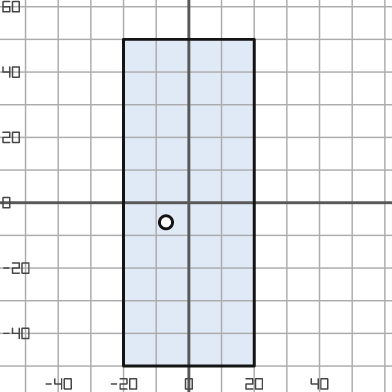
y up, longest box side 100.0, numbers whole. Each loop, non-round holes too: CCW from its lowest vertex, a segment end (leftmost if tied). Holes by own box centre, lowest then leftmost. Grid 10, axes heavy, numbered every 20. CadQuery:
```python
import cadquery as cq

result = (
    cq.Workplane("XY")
    .moveTo(-20.0, -50.0)
    .lineTo(20.0, -50.0)
    .lineTo(20.0, 50.0)
    .lineTo(-20.0, 50.0)
    .close()
    .moveTo(-7.0, -6.0)
    .circle(2.0)
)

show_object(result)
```